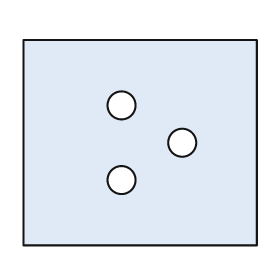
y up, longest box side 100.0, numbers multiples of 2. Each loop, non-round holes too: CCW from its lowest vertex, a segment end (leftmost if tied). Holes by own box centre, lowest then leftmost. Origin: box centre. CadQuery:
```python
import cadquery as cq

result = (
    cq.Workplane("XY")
    .moveTo(-50.0, -44.0)
    .lineTo(50.0, -44.0)
    .lineTo(50.0, 44.0)
    .lineTo(-50.0, 44.0)
    .close()
    .moveTo(-8.0, -16.0)
    .circle(6.0)
    .moveTo(18.0, 0.0)
    .circle(6.0)
    .moveTo(-8.0, 16.0)
    .circle(6.0)
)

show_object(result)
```